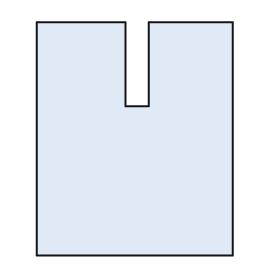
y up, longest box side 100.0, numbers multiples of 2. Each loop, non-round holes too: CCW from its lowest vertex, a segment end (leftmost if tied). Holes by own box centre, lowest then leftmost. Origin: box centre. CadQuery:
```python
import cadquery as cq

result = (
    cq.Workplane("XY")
    .moveTo(-42.0, -50.0)
    .lineTo(42.0, -50.0)
    .lineTo(42.0, 50.0)
    .lineTo(6.0, 50.0)
    .lineTo(6.0, 14.0)
    .lineTo(-4.0, 14.0)
    .lineTo(-4.0, 50.0)
    .lineTo(-42.0, 50.0)
    .close()
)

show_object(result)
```